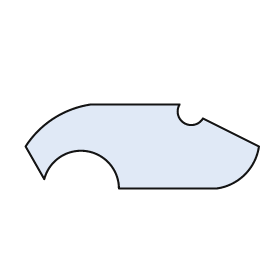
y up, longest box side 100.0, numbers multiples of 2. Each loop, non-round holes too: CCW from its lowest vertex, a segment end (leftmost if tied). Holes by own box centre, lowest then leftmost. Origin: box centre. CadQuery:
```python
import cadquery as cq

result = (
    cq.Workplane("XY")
    .moveTo(-10.0, -18.0)
    .lineTo(32.0, -18.0)
    .threePointArc((44.0, -12.0), (50.0, 0.0))
    .lineTo(26.0, 12.0)
    .threePointArc((18.0, 10.0), (16.0, 18.0))
    .lineTo(-22.0, 18.0)
    .threePointArc((-38.0, 12.0), (-50.0, 0.0))
    .lineTo(-42.0, -14.0)
    .threePointArc((-24.0, -2.0), (-10.0, -18.0))
    .close()
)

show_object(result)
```